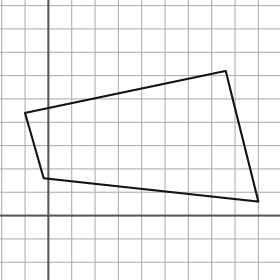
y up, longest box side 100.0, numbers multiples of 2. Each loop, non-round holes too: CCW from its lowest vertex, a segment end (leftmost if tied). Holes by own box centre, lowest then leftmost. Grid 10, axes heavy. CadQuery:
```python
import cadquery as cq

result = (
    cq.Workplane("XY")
    .moveTo(90.0, 6.0)
    .lineTo(76.0, 62.0)
    .lineTo(-10.0, 44.0)
    .lineTo(-2.0, 16.0)
    .close()
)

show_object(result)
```